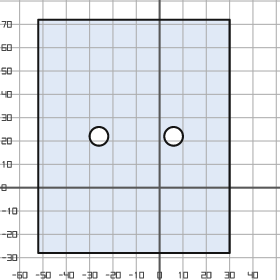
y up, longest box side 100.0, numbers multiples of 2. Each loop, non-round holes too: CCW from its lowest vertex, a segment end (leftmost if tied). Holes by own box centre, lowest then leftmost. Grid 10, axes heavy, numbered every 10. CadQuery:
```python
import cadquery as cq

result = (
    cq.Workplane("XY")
    .moveTo(-52.0, -28.0)
    .lineTo(30.0, -28.0)
    .lineTo(30.0, 72.0)
    .lineTo(-52.0, 72.0)
    .close()
    .moveTo(-26.0, 22.0)
    .circle(4.0)
    .moveTo(6.0, 22.0)
    .circle(4.0)
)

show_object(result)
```